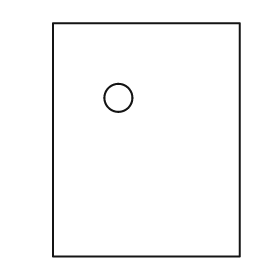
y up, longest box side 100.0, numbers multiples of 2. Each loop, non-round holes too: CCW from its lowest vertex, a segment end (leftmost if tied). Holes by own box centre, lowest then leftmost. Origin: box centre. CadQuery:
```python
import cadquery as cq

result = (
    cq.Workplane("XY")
    .moveTo(-40.0, -50.0)
    .lineTo(40.0, -50.0)
    .lineTo(40.0, 50.0)
    .lineTo(-40.0, 50.0)
    .close()
    .moveTo(-12.0, 18.0)
    .circle(6.0)
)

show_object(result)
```